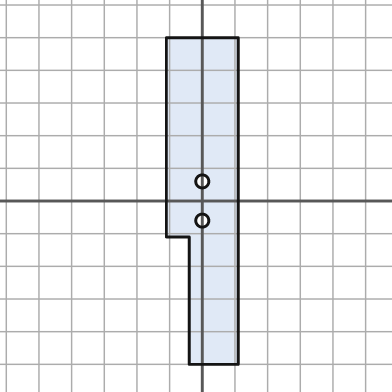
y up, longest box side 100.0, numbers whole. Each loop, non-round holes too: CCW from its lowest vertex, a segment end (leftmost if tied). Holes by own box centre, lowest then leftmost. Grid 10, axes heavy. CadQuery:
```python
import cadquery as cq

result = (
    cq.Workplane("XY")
    .moveTo(-4.0, -50.0)
    .lineTo(11.0, -50.0)
    .lineTo(11.0, 50.0)
    .lineTo(-11.0, 50.0)
    .lineTo(-11.0, -11.0)
    .lineTo(-4.0, -11.0)
    .close()
    .moveTo(0.0, -6.0)
    .circle(2.0)
    .moveTo(0.0, 6.0)
    .circle(2.0)
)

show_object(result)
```